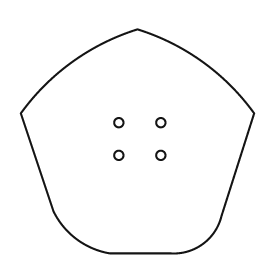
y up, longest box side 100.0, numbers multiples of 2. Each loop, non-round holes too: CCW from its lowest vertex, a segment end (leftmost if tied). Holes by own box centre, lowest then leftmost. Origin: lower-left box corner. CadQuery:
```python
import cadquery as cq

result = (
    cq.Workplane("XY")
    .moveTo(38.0, 0.0)
    .lineTo(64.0, 0.0)
    .threePointArc((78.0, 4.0), (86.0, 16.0))
    .lineTo(100.0, 60.0)
    .threePointArc((78.0, 82.0), (50.0, 96.0))
    .threePointArc((22.0, 82.0), (0.0, 60.0))
    .lineTo(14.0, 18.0)
    .threePointArc((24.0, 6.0), (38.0, 0.0))
    .close()
    .moveTo(42.0, 42.0)
    .circle(2.0)
    .moveTo(60.0, 42.0)
    .circle(2.0)
    .moveTo(42.0, 56.0)
    .circle(2.0)
    .moveTo(60.0, 56.0)
    .circle(2.0)
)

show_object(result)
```